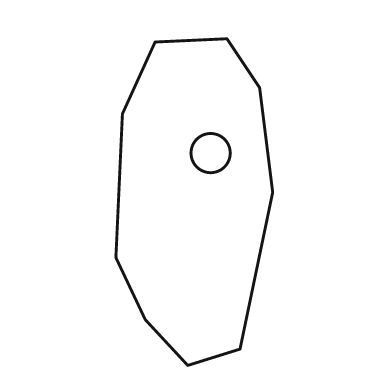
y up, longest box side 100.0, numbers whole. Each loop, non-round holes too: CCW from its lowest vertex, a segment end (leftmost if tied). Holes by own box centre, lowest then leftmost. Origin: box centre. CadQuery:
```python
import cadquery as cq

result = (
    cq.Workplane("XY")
    .moveTo(-2.0, -50.0)
    .lineTo(14.0, -45.0)
    .lineTo(24.0, 3.0)
    .lineTo(20.0, 35.0)
    .lineTo(10.0, 50.0)
    .lineTo(-12.0, 49.0)
    .lineTo(-22.0, 27.0)
    .lineTo(-24.0, -17.0)
    .lineTo(-15.0, -36.0)
    .close()
    .moveTo(5.0, 15.0)
    .circle(6.0)
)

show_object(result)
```